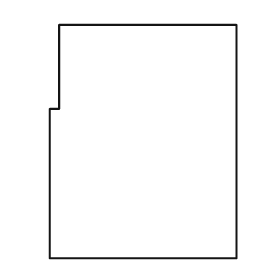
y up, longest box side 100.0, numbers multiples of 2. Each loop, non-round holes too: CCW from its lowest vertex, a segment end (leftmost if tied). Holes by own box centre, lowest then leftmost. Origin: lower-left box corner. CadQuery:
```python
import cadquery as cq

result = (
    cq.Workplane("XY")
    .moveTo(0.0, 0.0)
    .lineTo(80.0, 0.0)
    .lineTo(80.0, 100.0)
    .lineTo(4.0, 100.0)
    .lineTo(4.0, 64.0)
    .lineTo(0.0, 64.0)
    .close()
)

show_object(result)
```